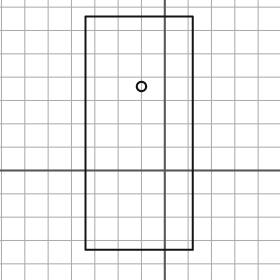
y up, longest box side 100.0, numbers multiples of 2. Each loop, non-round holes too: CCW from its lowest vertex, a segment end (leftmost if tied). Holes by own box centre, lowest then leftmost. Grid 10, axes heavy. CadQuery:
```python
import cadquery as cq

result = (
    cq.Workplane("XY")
    .moveTo(-34.0, -34.0)
    .lineTo(12.0, -34.0)
    .lineTo(12.0, 66.0)
    .lineTo(-34.0, 66.0)
    .close()
    .moveTo(-10.0, 36.0)
    .circle(2.0)
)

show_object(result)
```